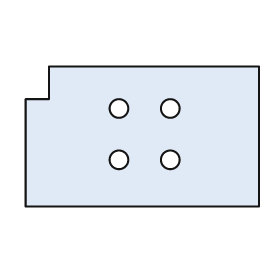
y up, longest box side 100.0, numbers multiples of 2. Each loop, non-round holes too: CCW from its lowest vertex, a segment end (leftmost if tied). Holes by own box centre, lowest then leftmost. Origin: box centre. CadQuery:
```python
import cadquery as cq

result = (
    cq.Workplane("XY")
    .moveTo(-50.0, -30.0)
    .lineTo(50.0, -30.0)
    .lineTo(50.0, 30.0)
    .lineTo(-40.0, 30.0)
    .lineTo(-40.0, 16.0)
    .lineTo(-50.0, 16.0)
    .close()
    .moveTo(-10.0, -10.0)
    .circle(4.0)
    .moveTo(12.0, -10.0)
    .circle(4.0)
    .moveTo(-10.0, 12.0)
    .circle(4.0)
    .moveTo(12.0, 12.0)
    .circle(4.0)
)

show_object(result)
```